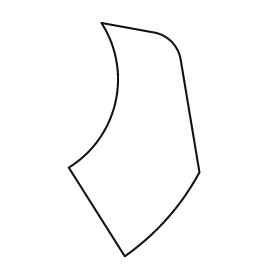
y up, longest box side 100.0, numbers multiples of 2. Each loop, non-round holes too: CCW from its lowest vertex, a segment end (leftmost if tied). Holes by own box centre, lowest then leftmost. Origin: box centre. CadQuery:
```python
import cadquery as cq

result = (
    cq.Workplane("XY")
    .moveTo(-4.0, -50.0)
    .threePointArc((14.0, -34.0), (28.0, -14.0))
    .lineTo(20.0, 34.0)
    .threePointArc((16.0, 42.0), (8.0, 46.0))
    .lineTo(-14.0, 50.0)
    .threePointArc((-8.0, 16.0), (-28.0, -12.0))
    .close()
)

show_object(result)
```